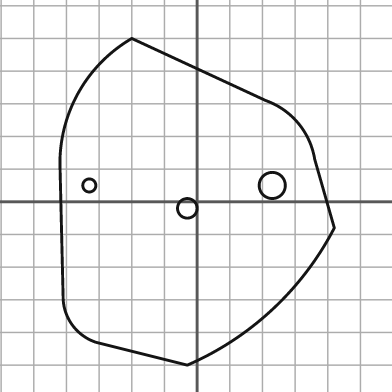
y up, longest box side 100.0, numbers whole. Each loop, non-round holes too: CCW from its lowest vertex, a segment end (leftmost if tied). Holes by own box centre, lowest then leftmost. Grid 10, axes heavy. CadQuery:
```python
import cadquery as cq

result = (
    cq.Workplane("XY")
    .moveTo(-3.0, -50.0)
    .threePointArc((23.0, -33.0), (42.0, -8.0))
    .lineTo(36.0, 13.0)
    .threePointArc((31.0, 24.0), (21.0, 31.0))
    .lineTo(-20.0, 50.0)
    .threePointArc((-36.0, 34.0), (-42.0, 12.0))
    .lineTo(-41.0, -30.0)
    .threePointArc((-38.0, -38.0), (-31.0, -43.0))
    .close()
    .moveTo(-3.0, -2.0)
    .circle(3.0)
    .moveTo(-33.0, 5.0)
    .circle(2.0)
    .moveTo(23.0, 5.0)
    .circle(4.0)
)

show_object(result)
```